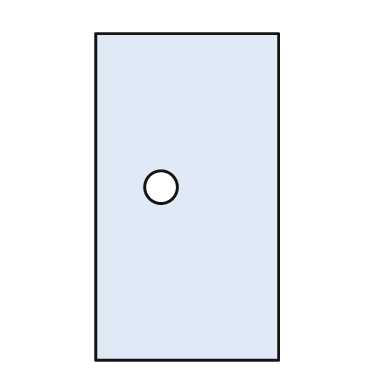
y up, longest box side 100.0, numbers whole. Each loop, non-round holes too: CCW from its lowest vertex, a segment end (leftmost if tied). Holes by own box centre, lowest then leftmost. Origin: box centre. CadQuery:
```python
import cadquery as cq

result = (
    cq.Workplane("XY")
    .moveTo(-28.0, -50.0)
    .lineTo(28.0, -50.0)
    .lineTo(28.0, 50.0)
    .lineTo(-28.0, 50.0)
    .close()
    .moveTo(-8.0, 3.0)
    .circle(5.0)
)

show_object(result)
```